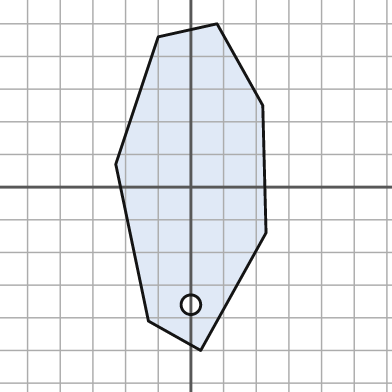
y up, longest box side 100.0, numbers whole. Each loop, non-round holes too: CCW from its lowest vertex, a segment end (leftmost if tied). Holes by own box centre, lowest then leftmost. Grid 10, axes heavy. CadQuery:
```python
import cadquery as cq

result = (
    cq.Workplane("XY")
    .moveTo(3.0, -50.0)
    .lineTo(23.0, -14.0)
    .lineTo(22.0, 25.0)
    .lineTo(8.0, 50.0)
    .lineTo(-10.0, 46.0)
    .lineTo(-23.0, 7.0)
    .lineTo(-13.0, -41.0)
    .close()
    .moveTo(0.0, -36.0)
    .circle(3.0)
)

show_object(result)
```